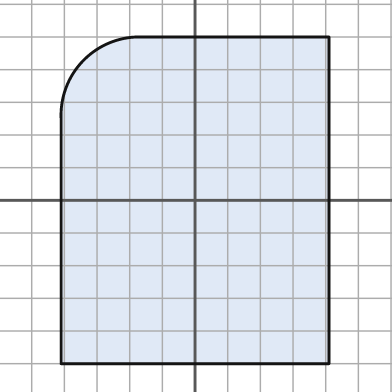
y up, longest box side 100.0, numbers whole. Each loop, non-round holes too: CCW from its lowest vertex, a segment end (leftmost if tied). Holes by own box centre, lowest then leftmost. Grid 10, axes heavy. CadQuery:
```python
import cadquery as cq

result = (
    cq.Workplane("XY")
    .moveTo(-41.0, -50.0)
    .lineTo(41.0, -50.0)
    .lineTo(41.0, 50.0)
    .lineTo(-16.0, 50.0)
    .threePointArc((-34.0, 43.0), (-41.0, 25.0))
    .close()
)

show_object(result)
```